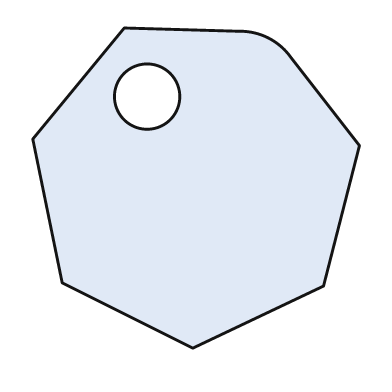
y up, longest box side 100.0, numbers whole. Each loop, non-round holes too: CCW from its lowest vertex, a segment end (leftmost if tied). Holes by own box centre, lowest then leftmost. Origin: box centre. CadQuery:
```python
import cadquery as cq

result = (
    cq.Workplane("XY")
    .moveTo(-1.0, -49.0)
    .lineTo(39.0, -30.0)
    .lineTo(50.0, 13.0)
    .lineTo(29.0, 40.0)
    .threePointArc((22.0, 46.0), (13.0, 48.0))
    .lineTo(-22.0, 49.0)
    .lineTo(-50.0, 15.0)
    .lineTo(-41.0, -29.0)
    .close()
    .moveTo(-15.0, 28.0)
    .circle(10.0)
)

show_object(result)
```